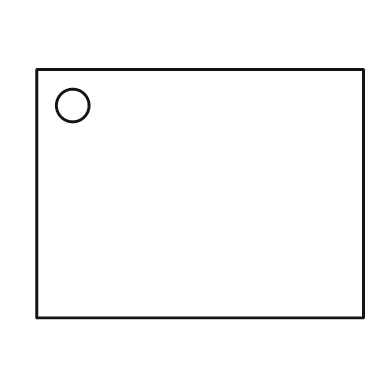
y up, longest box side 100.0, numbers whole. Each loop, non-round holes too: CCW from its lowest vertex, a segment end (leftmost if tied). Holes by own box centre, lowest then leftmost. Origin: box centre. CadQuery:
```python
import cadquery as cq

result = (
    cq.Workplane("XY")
    .moveTo(-50.0, -38.0)
    .lineTo(50.0, -38.0)
    .lineTo(50.0, 38.0)
    .lineTo(-50.0, 38.0)
    .close()
    .moveTo(-39.0, 27.0)
    .circle(5.0)
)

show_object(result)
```